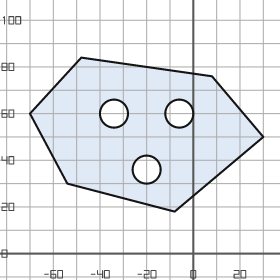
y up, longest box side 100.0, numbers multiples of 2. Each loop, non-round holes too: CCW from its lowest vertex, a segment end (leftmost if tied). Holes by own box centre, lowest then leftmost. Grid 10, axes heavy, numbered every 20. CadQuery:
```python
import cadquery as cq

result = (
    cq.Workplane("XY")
    .moveTo(-8.0, 18.0)
    .lineTo(30.0, 50.0)
    .lineTo(8.0, 76.0)
    .lineTo(-48.0, 84.0)
    .lineTo(-70.0, 60.0)
    .lineTo(-54.0, 30.0)
    .close()
    .moveTo(-20.0, 36.0)
    .circle(6.0)
    .moveTo(-34.0, 60.0)
    .circle(6.0)
    .moveTo(-6.0, 60.0)
    .circle(6.0)
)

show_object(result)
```